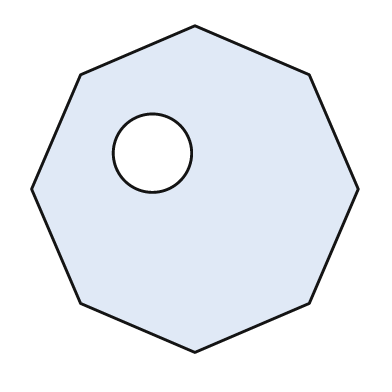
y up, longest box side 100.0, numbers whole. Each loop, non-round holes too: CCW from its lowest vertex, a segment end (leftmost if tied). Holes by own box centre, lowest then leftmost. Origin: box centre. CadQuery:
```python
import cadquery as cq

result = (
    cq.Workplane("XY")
    .moveTo(0.0, -50.0)
    .lineTo(35.0, -35.0)
    .lineTo(50.0, 0.0)
    .lineTo(35.0, 35.0)
    .lineTo(0.0, 50.0)
    .lineTo(-35.0, 35.0)
    .lineTo(-50.0, 0.0)
    .lineTo(-35.0, -35.0)
    .close()
    .moveTo(-13.0, 11.0)
    .circle(12.0)
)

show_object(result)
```